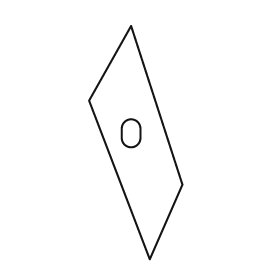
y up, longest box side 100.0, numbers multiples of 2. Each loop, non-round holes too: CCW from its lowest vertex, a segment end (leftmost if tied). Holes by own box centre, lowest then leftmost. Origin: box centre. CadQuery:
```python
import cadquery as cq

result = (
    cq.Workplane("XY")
    .moveTo(6.0, -50.0)
    .lineTo(20.0, -18.0)
    .lineTo(-2.0, 50.0)
    .lineTo(-20.0, 18.0)
    .close()
    .moveTo(-6.0, 2.0)
    .threePointArc((-2.0, -2.0), (2.0, 2.0))
    .lineTo(2.0, 6.0)
    .threePointArc((-2.0, 10.0), (-6.0, 6.0))
    .close()
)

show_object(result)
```